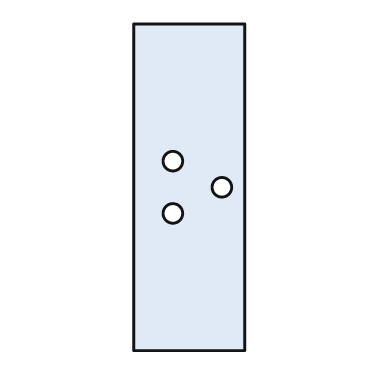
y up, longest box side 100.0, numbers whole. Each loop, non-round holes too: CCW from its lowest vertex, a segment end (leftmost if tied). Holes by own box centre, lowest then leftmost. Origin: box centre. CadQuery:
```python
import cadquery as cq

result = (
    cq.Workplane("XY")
    .moveTo(-17.0, -50.0)
    .lineTo(17.0, -50.0)
    .lineTo(17.0, 50.0)
    .lineTo(-17.0, 50.0)
    .close()
    .moveTo(-5.0, -8.0)
    .circle(3.0)
    .moveTo(10.0, 0.0)
    .circle(3.0)
    .moveTo(-5.0, 8.0)
    .circle(3.0)
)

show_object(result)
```